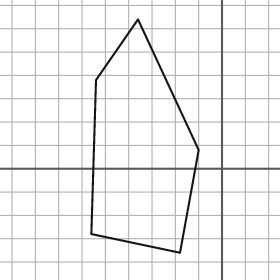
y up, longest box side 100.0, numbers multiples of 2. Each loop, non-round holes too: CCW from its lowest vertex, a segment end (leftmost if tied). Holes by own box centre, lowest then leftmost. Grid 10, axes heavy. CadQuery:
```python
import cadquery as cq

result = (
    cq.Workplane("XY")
    .moveTo(-18.0, -36.0)
    .lineTo(-10.0, 8.0)
    .lineTo(-36.0, 64.0)
    .lineTo(-54.0, 38.0)
    .lineTo(-56.0, -28.0)
    .close()
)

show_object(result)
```